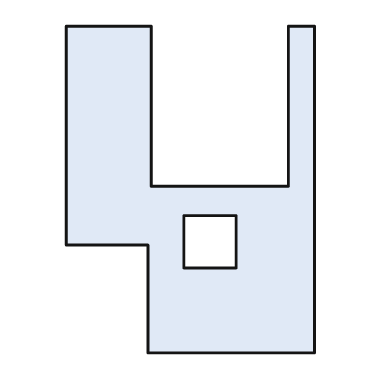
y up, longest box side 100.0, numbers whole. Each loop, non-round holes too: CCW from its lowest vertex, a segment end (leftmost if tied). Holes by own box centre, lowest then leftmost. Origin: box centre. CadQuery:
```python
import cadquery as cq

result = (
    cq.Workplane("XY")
    .moveTo(-13.0, -50.0)
    .lineTo(38.0, -50.0)
    .lineTo(38.0, 50.0)
    .lineTo(30.0, 50.0)
    .lineTo(30.0, 1.0)
    .lineTo(-12.0, 1.0)
    .lineTo(-12.0, 50.0)
    .lineTo(-38.0, 50.0)
    .lineTo(-38.0, -17.0)
    .lineTo(-13.0, -17.0)
    .close()
    .moveTo(-2.0, -24.0)
    .lineTo(14.0, -24.0)
    .lineTo(14.0, -8.0)
    .lineTo(-2.0, -8.0)
    .close()
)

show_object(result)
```